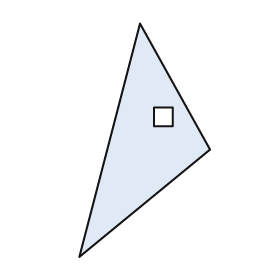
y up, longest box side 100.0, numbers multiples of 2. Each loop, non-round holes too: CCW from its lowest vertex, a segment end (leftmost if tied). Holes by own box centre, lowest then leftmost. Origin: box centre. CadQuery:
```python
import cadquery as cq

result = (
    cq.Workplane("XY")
    .moveTo(-28.0, -50.0)
    .lineTo(28.0, -4.0)
    .lineTo(-2.0, 50.0)
    .close()
    .moveTo(4.0, 6.0)
    .lineTo(12.0, 6.0)
    .lineTo(12.0, 14.0)
    .lineTo(4.0, 14.0)
    .close()
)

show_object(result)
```